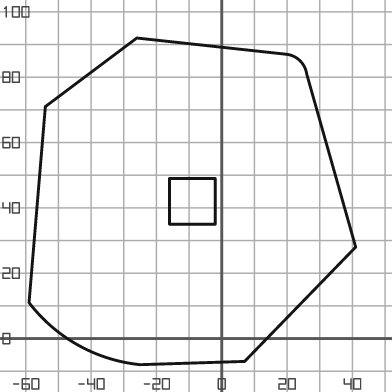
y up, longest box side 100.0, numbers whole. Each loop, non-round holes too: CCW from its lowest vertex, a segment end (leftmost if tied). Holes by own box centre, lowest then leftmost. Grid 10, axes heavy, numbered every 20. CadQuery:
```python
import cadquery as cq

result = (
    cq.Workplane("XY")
    .moveTo(-25.0, -8.0)
    .lineTo(7.0, -7.0)
    .lineTo(41.0, 28.0)
    .lineTo(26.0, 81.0)
    .threePointArc((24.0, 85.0), (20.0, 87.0))
    .lineTo(-26.0, 92.0)
    .lineTo(-54.0, 71.0)
    .lineTo(-59.0, 11.0)
    .threePointArc((-44.0, -2.0), (-25.0, -8.0))
    .close()
    .moveTo(-16.0, 35.0)
    .lineTo(-2.0, 35.0)
    .lineTo(-2.0, 49.0)
    .lineTo(-16.0, 49.0)
    .close()
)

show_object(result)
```